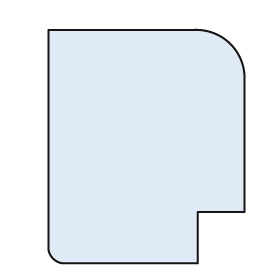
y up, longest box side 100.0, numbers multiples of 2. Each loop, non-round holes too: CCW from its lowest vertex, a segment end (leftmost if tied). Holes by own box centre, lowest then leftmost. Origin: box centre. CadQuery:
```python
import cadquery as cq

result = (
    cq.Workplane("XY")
    .moveTo(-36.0, -50.0)
    .lineTo(22.0, -50.0)
    .lineTo(22.0, -28.0)
    .lineTo(42.0, -28.0)
    .lineTo(42.0, 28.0)
    .threePointArc((36.0, 44.0), (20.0, 50.0))
    .lineTo(-42.0, 50.0)
    .lineTo(-42.0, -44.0)
    .threePointArc((-40.0, -48.0), (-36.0, -50.0))
    .close()
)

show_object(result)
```